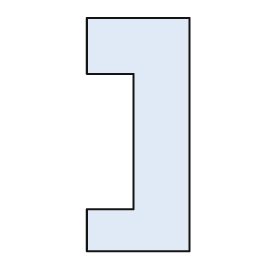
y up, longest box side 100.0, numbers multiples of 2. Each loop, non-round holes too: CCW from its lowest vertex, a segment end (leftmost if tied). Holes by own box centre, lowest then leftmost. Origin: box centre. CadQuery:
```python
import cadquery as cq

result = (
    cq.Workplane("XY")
    .moveTo(-22.0, -50.0)
    .lineTo(22.0, -50.0)
    .lineTo(22.0, 50.0)
    .lineTo(-22.0, 50.0)
    .lineTo(-22.0, 26.0)
    .lineTo(-2.0, 26.0)
    .lineTo(-2.0, -32.0)
    .lineTo(-22.0, -32.0)
    .close()
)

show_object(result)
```